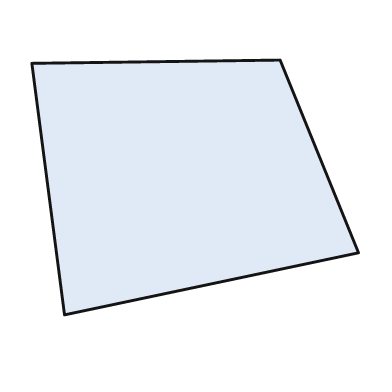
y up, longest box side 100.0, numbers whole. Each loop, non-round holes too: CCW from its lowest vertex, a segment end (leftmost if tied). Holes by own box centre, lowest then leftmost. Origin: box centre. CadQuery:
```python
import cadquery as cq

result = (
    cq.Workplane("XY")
    .moveTo(-40.0, -39.0)
    .lineTo(50.0, -20.0)
    .lineTo(26.0, 39.0)
    .lineTo(-50.0, 38.0)
    .close()
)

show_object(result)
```